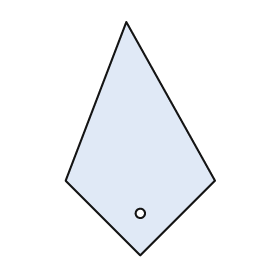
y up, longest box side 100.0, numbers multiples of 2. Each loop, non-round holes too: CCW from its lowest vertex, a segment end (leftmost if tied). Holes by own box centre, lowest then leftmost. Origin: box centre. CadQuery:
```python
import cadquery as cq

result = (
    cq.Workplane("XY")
    .moveTo(0.0, -50.0)
    .lineTo(32.0, -18.0)
    .lineTo(-6.0, 50.0)
    .lineTo(-32.0, -18.0)
    .close()
    .moveTo(0.0, -32.0)
    .circle(2.0)
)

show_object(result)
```